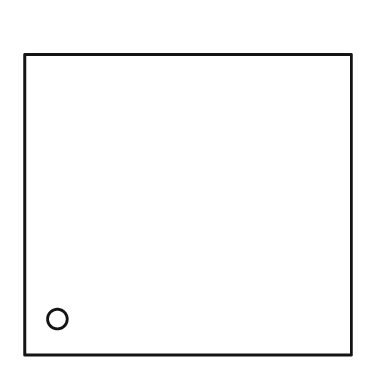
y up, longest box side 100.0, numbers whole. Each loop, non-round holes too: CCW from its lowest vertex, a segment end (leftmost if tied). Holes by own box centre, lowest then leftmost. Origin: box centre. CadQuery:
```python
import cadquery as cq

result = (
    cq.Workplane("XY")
    .moveTo(-50.0, -46.0)
    .lineTo(50.0, -46.0)
    .lineTo(50.0, 46.0)
    .lineTo(-50.0, 46.0)
    .close()
    .moveTo(-40.0, -35.0)
    .circle(3.0)
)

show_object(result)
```